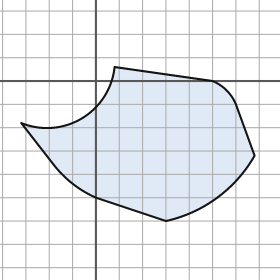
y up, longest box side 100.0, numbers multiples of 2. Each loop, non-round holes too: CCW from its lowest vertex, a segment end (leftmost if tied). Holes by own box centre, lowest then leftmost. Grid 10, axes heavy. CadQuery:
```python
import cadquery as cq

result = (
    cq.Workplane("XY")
    .moveTo(30.0, -60.0)
    .threePointArc((52.0, -50.0), (68.0, -32.0))
    .lineTo(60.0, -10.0)
    .threePointArc((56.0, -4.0), (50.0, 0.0))
    .lineTo(8.0, 6.0)
    .threePointArc((-6.0, -16.0), (-32.0, -18.0))
    .lineTo(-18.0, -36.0)
    .threePointArc((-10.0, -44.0), (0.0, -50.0))
    .close()
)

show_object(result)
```